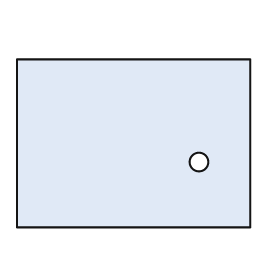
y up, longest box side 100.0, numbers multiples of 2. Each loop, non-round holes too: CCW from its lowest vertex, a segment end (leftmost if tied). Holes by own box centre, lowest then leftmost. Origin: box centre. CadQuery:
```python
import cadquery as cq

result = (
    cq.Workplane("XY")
    .moveTo(-50.0, -36.0)
    .lineTo(50.0, -36.0)
    .lineTo(50.0, 36.0)
    .lineTo(-50.0, 36.0)
    .close()
    .moveTo(28.0, -8.0)
    .circle(4.0)
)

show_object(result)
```